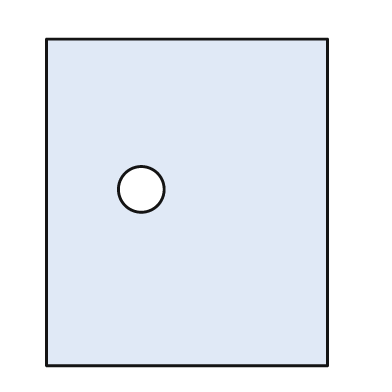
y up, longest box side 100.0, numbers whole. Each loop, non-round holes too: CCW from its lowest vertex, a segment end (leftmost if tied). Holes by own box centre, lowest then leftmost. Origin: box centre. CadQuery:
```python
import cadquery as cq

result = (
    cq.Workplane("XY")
    .moveTo(-43.0, -50.0)
    .lineTo(43.0, -50.0)
    .lineTo(43.0, 50.0)
    .lineTo(-43.0, 50.0)
    .close()
    .moveTo(-14.0, 4.0)
    .circle(7.0)
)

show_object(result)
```